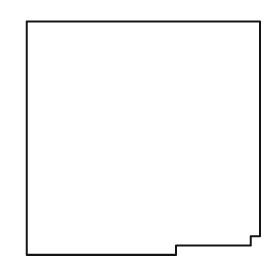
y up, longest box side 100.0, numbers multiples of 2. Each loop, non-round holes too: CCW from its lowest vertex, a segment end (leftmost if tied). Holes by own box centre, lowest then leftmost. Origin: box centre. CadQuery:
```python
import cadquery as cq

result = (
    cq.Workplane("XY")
    .moveTo(-50.0, -50.0)
    .lineTo(14.0, -50.0)
    .lineTo(14.0, -46.0)
    .lineTo(46.0, -46.0)
    .lineTo(46.0, -42.0)
    .lineTo(50.0, -42.0)
    .lineTo(50.0, 50.0)
    .lineTo(-50.0, 50.0)
    .close()
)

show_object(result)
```